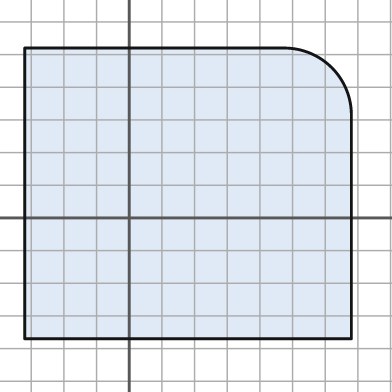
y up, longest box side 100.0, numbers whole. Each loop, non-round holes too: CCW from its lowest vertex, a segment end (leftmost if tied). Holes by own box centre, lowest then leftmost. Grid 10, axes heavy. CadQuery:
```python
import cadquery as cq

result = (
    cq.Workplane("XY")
    .moveTo(-32.0, -37.0)
    .lineTo(68.0, -37.0)
    .lineTo(68.0, 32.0)
    .threePointArc((62.0, 46.0), (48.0, 52.0))
    .lineTo(-32.0, 52.0)
    .close()
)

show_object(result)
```